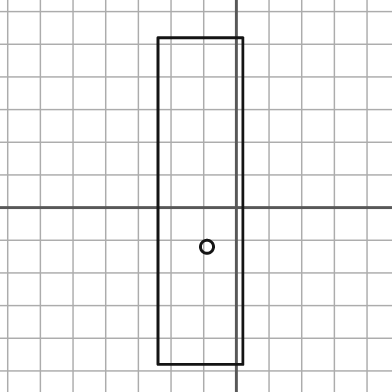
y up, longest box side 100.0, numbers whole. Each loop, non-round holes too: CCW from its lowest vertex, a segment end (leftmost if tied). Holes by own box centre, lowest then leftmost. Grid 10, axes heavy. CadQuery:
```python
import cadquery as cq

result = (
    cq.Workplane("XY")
    .moveTo(-24.0, -48.0)
    .lineTo(2.0, -48.0)
    .lineTo(2.0, 52.0)
    .lineTo(-24.0, 52.0)
    .close()
    .moveTo(-9.0, -12.0)
    .circle(2.0)
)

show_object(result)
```